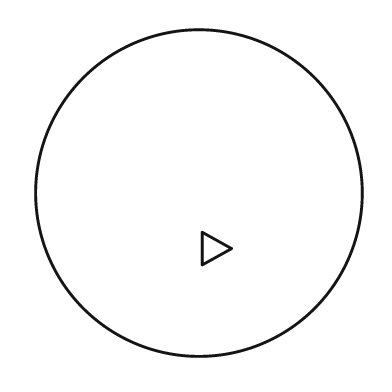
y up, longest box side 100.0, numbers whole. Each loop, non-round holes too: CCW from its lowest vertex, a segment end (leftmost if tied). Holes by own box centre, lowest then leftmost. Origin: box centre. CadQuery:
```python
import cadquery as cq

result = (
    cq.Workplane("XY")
    .moveTo(0.0, 0.0)
    .circle(50.0)
    .moveTo(1.0, -22.0)
    .lineTo(10.0, -17.0)
    .lineTo(1.0, -12.0)
    .close()
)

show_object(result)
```